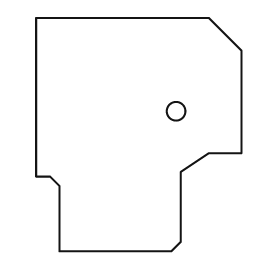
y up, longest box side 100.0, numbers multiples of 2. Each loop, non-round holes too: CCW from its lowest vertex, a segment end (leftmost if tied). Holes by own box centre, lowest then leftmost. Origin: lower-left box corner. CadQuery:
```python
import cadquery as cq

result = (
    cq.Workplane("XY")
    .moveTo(10.0, 0.0)
    .lineTo(58.0, 0.0)
    .lineTo(62.0, 4.0)
    .lineTo(62.0, 34.0)
    .lineTo(74.0, 42.0)
    .lineTo(88.0, 42.0)
    .lineTo(88.0, 86.0)
    .lineTo(74.0, 100.0)
    .lineTo(0.0, 100.0)
    .lineTo(0.0, 32.0)
    .lineTo(6.0, 32.0)
    .lineTo(10.0, 28.0)
    .close()
    .moveTo(60.0, 60.0)
    .circle(4.0)
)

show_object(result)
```